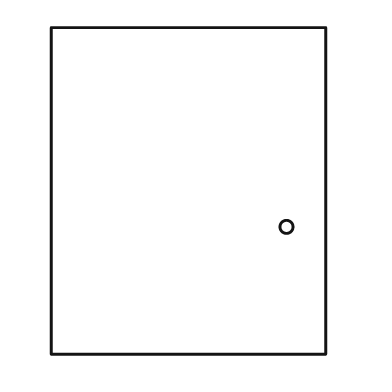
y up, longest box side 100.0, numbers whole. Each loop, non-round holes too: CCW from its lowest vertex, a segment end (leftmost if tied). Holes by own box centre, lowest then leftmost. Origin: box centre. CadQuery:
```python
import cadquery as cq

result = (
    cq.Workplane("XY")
    .moveTo(-42.0, -50.0)
    .lineTo(42.0, -50.0)
    .lineTo(42.0, 50.0)
    .lineTo(-42.0, 50.0)
    .close()
    .moveTo(30.0, -11.0)
    .circle(2.0)
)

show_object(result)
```